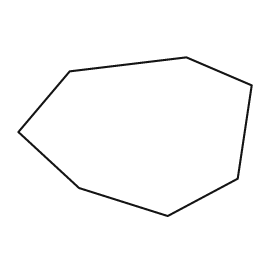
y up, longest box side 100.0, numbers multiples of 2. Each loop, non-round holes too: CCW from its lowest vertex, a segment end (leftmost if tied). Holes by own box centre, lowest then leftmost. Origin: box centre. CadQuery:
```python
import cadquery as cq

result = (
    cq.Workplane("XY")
    .moveTo(14.0, -34.0)
    .lineTo(44.0, -18.0)
    .lineTo(50.0, 22.0)
    .lineTo(22.0, 34.0)
    .lineTo(-28.0, 28.0)
    .lineTo(-50.0, 2.0)
    .lineTo(-24.0, -22.0)
    .close()
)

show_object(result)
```